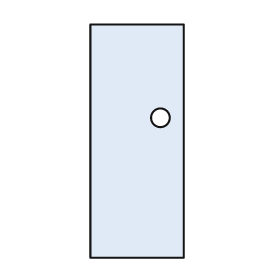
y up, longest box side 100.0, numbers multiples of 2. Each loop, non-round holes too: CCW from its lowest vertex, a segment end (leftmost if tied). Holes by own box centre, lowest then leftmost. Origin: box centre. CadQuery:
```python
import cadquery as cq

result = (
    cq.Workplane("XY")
    .moveTo(-20.0, -50.0)
    .lineTo(20.0, -50.0)
    .lineTo(20.0, 50.0)
    .lineTo(-20.0, 50.0)
    .close()
    .moveTo(10.0, 10.0)
    .circle(4.0)
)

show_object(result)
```